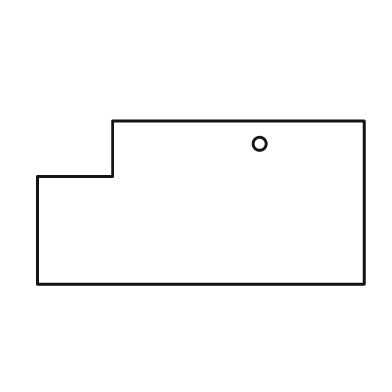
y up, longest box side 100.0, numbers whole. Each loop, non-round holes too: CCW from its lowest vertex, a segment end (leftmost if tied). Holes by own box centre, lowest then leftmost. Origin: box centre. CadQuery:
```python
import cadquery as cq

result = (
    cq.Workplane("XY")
    .moveTo(-50.0, -25.0)
    .lineTo(50.0, -25.0)
    .lineTo(50.0, 25.0)
    .lineTo(-27.0, 25.0)
    .lineTo(-27.0, 8.0)
    .lineTo(-50.0, 8.0)
    .close()
    .moveTo(18.0, 18.0)
    .circle(2.0)
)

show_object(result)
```